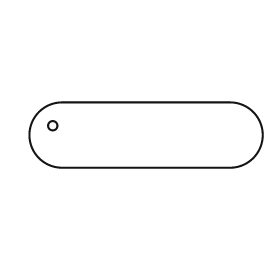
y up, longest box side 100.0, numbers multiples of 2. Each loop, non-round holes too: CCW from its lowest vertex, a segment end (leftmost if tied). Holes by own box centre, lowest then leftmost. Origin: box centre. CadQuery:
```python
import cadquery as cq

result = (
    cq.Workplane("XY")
    .moveTo(-36.0, -14.0)
    .lineTo(36.0, -14.0)
    .threePointArc((50.0, 0.0), (36.0, 14.0))
    .lineTo(-36.0, 14.0)
    .threePointArc((-50.0, 0.0), (-36.0, -14.0))
    .close()
    .moveTo(-40.0, 4.0)
    .circle(2.0)
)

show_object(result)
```